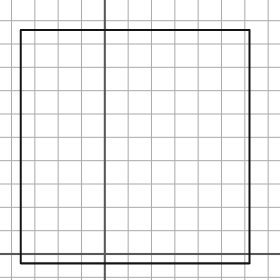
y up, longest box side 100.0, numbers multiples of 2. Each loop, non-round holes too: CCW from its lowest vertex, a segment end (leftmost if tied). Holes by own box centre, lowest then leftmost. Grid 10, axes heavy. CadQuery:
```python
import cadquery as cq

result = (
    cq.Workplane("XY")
    .moveTo(-36.0, -4.0)
    .lineTo(62.0, -4.0)
    .lineTo(62.0, 96.0)
    .lineTo(-36.0, 96.0)
    .close()
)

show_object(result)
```